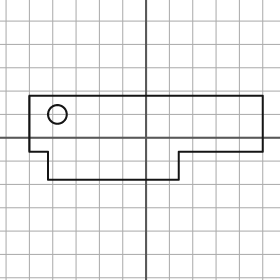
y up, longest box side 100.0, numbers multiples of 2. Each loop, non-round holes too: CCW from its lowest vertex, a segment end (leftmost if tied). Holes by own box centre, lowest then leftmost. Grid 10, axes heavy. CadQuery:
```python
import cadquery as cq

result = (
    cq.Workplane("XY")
    .moveTo(-42.0, -18.0)
    .lineTo(14.0, -18.0)
    .lineTo(14.0, -6.0)
    .lineTo(50.0, -6.0)
    .lineTo(50.0, 18.0)
    .lineTo(-50.0, 18.0)
    .lineTo(-50.0, -6.0)
    .lineTo(-42.0, -6.0)
    .close()
    .moveTo(-38.0, 10.0)
    .circle(4.0)
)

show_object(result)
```